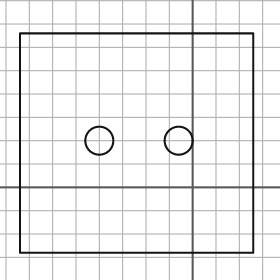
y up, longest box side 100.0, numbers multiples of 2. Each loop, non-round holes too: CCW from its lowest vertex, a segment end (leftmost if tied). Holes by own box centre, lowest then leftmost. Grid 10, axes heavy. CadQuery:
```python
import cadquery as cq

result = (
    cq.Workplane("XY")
    .moveTo(-74.0, -28.0)
    .lineTo(26.0, -28.0)
    .lineTo(26.0, 66.0)
    .lineTo(-74.0, 66.0)
    .close()
    .moveTo(-40.0, 20.0)
    .circle(6.0)
    .moveTo(-6.0, 20.0)
    .circle(6.0)
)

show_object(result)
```